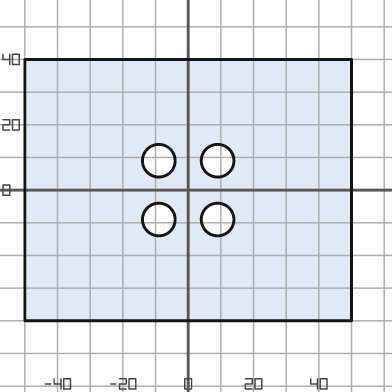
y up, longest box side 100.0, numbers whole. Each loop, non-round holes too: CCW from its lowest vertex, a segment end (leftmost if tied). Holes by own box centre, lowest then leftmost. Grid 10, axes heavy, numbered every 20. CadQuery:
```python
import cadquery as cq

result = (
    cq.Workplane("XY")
    .moveTo(-50.0, -40.0)
    .lineTo(50.0, -40.0)
    .lineTo(50.0, 40.0)
    .lineTo(-50.0, 40.0)
    .close()
    .moveTo(-9.0, -9.0)
    .circle(5.0)
    .moveTo(9.0, -9.0)
    .circle(5.0)
    .moveTo(-9.0, 9.0)
    .circle(5.0)
    .moveTo(9.0, 9.0)
    .circle(5.0)
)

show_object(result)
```